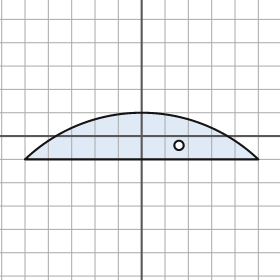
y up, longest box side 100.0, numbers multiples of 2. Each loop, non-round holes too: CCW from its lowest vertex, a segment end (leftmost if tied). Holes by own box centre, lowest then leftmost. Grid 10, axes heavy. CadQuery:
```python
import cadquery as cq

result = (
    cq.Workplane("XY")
    .moveTo(-50.0, -10.0)
    .lineTo(50.0, -10.0)
    .threePointArc((0.0, 10.0), (-50.0, -10.0))
    .close()
    .moveTo(16.0, -4.0)
    .circle(2.0)
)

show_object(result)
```